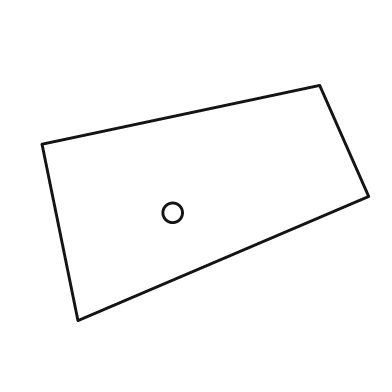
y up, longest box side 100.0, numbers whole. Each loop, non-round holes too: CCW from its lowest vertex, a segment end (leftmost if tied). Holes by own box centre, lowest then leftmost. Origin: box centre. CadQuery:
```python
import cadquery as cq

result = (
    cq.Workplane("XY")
    .moveTo(-39.0, -36.0)
    .lineTo(50.0, 2.0)
    .lineTo(35.0, 36.0)
    .lineTo(-50.0, 18.0)
    .close()
    .moveTo(-10.0, -3.0)
    .circle(3.0)
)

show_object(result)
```